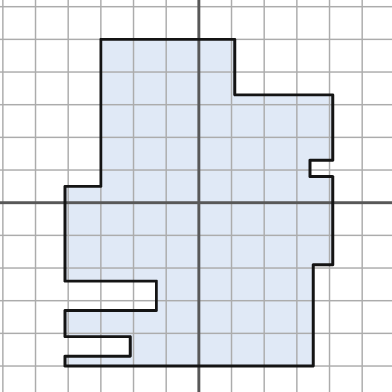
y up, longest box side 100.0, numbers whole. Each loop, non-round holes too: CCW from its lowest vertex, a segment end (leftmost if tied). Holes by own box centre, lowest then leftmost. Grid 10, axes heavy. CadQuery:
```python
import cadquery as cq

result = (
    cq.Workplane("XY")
    .moveTo(-41.0, -50.0)
    .lineTo(35.0, -50.0)
    .lineTo(35.0, -19.0)
    .lineTo(41.0, -19.0)
    .lineTo(41.0, 8.0)
    .lineTo(34.0, 8.0)
    .lineTo(34.0, 13.0)
    .lineTo(41.0, 13.0)
    .lineTo(41.0, 33.0)
    .lineTo(11.0, 33.0)
    .lineTo(11.0, 50.0)
    .lineTo(-30.0, 50.0)
    .lineTo(-30.0, 5.0)
    .lineTo(-41.0, 5.0)
    .lineTo(-41.0, -24.0)
    .lineTo(-13.0, -24.0)
    .lineTo(-13.0, -33.0)
    .lineTo(-41.0, -33.0)
    .lineTo(-41.0, -41.0)
    .lineTo(-21.0, -41.0)
    .lineTo(-21.0, -47.0)
    .lineTo(-41.0, -47.0)
    .close()
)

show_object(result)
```